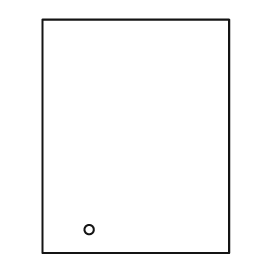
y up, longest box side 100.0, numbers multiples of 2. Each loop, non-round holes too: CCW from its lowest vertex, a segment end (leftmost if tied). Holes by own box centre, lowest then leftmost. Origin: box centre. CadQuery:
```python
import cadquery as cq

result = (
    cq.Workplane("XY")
    .moveTo(-40.0, -50.0)
    .lineTo(40.0, -50.0)
    .lineTo(40.0, 50.0)
    .lineTo(-40.0, 50.0)
    .close()
    .moveTo(-20.0, -40.0)
    .circle(2.0)
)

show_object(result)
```